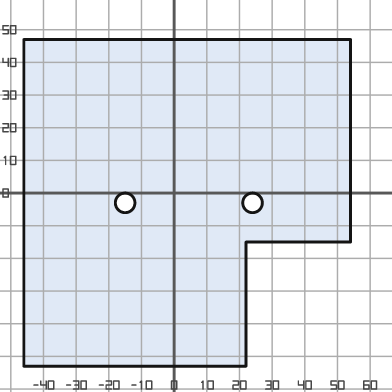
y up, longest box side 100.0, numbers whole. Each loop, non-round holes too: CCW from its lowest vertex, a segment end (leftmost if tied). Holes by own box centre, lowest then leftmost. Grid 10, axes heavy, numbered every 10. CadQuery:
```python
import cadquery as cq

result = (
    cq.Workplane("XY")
    .moveTo(-46.0, -53.0)
    .lineTo(22.0, -53.0)
    .lineTo(22.0, -15.0)
    .lineTo(54.0, -15.0)
    .lineTo(54.0, 47.0)
    .lineTo(-46.0, 47.0)
    .close()
    .moveTo(-15.0, -3.0)
    .circle(3.0)
    .moveTo(24.0, -3.0)
    .circle(3.0)
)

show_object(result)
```